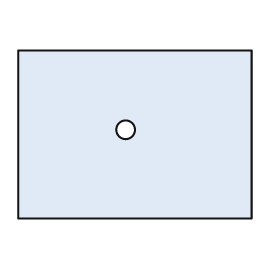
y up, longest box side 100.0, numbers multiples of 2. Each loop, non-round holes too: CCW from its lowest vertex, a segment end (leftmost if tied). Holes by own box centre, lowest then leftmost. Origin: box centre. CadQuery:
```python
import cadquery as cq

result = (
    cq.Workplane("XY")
    .moveTo(-50.0, -36.0)
    .lineTo(50.0, -36.0)
    .lineTo(50.0, 36.0)
    .lineTo(-50.0, 36.0)
    .close()
    .moveTo(-4.0, 2.0)
    .circle(4.0)
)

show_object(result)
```